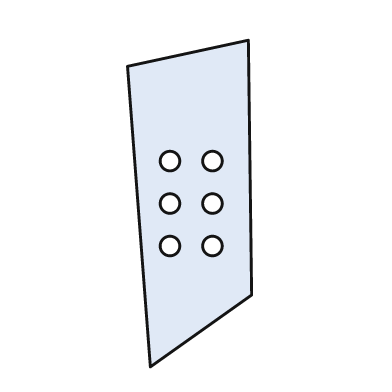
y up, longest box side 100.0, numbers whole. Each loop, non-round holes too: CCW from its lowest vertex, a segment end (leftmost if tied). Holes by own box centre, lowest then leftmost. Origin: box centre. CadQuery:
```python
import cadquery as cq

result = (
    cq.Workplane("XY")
    .moveTo(-12.0, -50.0)
    .lineTo(19.0, -28.0)
    .lineTo(18.0, 50.0)
    .lineTo(-19.0, 42.0)
    .close()
    .moveTo(-6.0, -13.0)
    .circle(3.0)
    .moveTo(7.0, -13.0)
    .circle(3.0)
    .moveTo(-6.0, 0.0)
    .circle(3.0)
    .moveTo(7.0, 0.0)
    .circle(3.0)
    .moveTo(-6.0, 13.0)
    .circle(3.0)
    .moveTo(7.0, 13.0)
    .circle(3.0)
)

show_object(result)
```